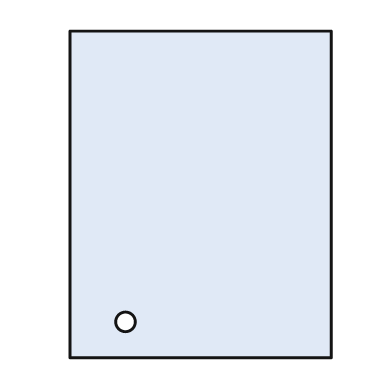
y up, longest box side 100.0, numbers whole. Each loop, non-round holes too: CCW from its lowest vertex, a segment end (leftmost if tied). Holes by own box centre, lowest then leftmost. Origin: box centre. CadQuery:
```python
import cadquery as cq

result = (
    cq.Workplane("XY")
    .moveTo(-40.0, -50.0)
    .lineTo(40.0, -50.0)
    .lineTo(40.0, 50.0)
    .lineTo(-40.0, 50.0)
    .close()
    .moveTo(-23.0, -39.0)
    .circle(3.0)
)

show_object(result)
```